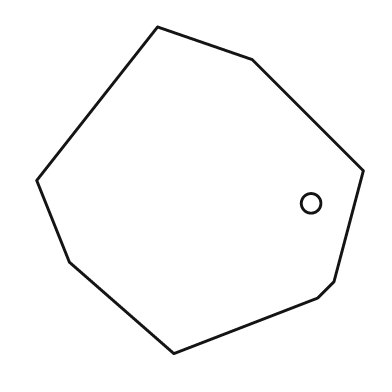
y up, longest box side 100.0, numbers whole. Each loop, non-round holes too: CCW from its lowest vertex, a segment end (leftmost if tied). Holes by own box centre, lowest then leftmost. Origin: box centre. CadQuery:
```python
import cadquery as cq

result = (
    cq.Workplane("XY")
    .moveTo(-8.0, -50.0)
    .lineTo(36.0, -33.0)
    .lineTo(41.0, -28.0)
    .lineTo(50.0, 6.0)
    .lineTo(16.0, 40.0)
    .lineTo(-13.0, 50.0)
    .lineTo(-50.0, 3.0)
    .lineTo(-40.0, -22.0)
    .close()
    .moveTo(34.0, -4.0)
    .circle(3.0)
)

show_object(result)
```